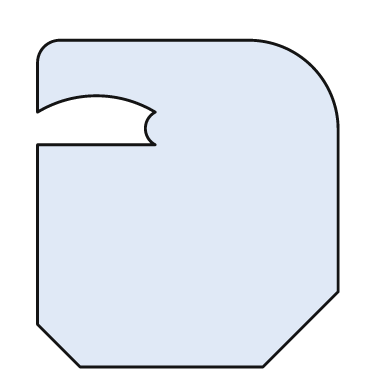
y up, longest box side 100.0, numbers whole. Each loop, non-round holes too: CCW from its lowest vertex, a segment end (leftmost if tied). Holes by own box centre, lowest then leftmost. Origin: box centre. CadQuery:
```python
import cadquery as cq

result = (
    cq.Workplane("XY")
    .moveTo(-33.0, -50.0)
    .lineTo(23.0, -50.0)
    .lineTo(46.0, -27.0)
    .lineTo(46.0, 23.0)
    .threePointArc((38.0, 42.0), (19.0, 50.0))
    .lineTo(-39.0, 50.0)
    .threePointArc((-44.0, 48.0), (-46.0, 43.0))
    .lineTo(-46.0, 28.0)
    .threePointArc((-28.0, 33.0), (-10.0, 28.0))
    .threePointArc((-13.0, 23.0), (-10.0, 18.0))
    .lineTo(-46.0, 18.0)
    .lineTo(-46.0, -37.0)
    .close()
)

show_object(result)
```